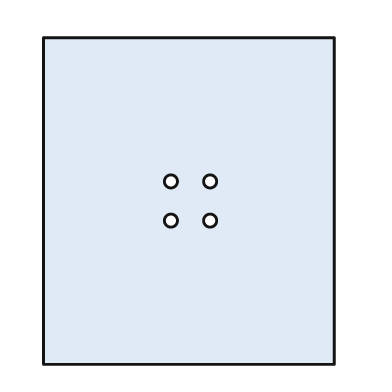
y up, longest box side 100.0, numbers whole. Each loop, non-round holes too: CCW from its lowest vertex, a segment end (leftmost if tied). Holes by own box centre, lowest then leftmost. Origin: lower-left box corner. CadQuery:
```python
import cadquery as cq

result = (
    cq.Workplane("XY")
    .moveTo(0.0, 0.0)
    .lineTo(89.0, 0.0)
    .lineTo(89.0, 100.0)
    .lineTo(0.0, 100.0)
    .close()
    .moveTo(39.0, 44.0)
    .circle(2.0)
    .moveTo(51.0, 44.0)
    .circle(2.0)
    .moveTo(39.0, 56.0)
    .circle(2.0)
    .moveTo(51.0, 56.0)
    .circle(2.0)
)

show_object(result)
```